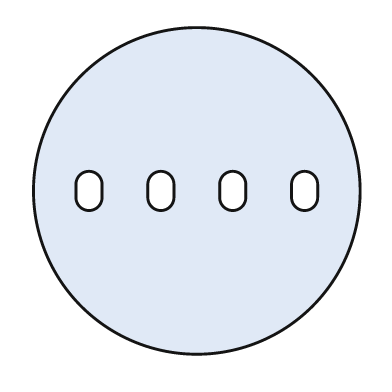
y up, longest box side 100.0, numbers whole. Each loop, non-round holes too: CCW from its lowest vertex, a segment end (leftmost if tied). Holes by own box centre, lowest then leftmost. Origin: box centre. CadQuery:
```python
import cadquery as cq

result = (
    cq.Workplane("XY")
    .moveTo(0.0, 0.0)
    .circle(50.0)
    .moveTo(-37.0, -2.0)
    .threePointArc((-33.0, -6.0), (-29.0, -2.0))
    .lineTo(-29.0, 2.0)
    .threePointArc((-33.0, 6.0), (-37.0, 2.0))
    .close()
    .moveTo(-15.0, -2.0)
    .threePointArc((-11.0, -6.0), (-7.0, -2.0))
    .lineTo(-7.0, 2.0)
    .threePointArc((-11.0, 6.0), (-15.0, 2.0))
    .close()
    .moveTo(7.0, -2.0)
    .threePointArc((11.0, -6.0), (15.0, -2.0))
    .lineTo(15.0, 2.0)
    .threePointArc((11.0, 6.0), (7.0, 2.0))
    .close()
    .moveTo(29.0, -2.0)
    .threePointArc((33.0, -6.0), (37.0, -2.0))
    .lineTo(37.0, 2.0)
    .threePointArc((33.0, 6.0), (29.0, 2.0))
    .close()
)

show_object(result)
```